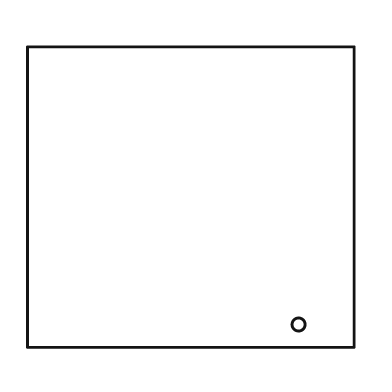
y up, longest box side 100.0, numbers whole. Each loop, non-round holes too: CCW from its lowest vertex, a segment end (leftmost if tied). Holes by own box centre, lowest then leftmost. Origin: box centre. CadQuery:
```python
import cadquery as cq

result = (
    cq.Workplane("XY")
    .moveTo(-50.0, -46.0)
    .lineTo(50.0, -46.0)
    .lineTo(50.0, 46.0)
    .lineTo(-50.0, 46.0)
    .close()
    .moveTo(33.0, -39.0)
    .circle(2.0)
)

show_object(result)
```